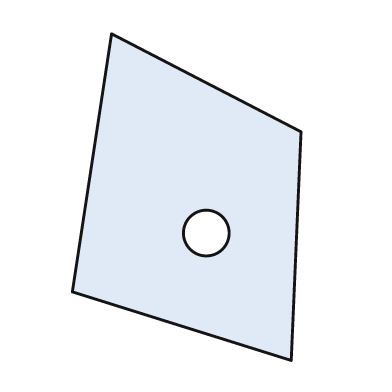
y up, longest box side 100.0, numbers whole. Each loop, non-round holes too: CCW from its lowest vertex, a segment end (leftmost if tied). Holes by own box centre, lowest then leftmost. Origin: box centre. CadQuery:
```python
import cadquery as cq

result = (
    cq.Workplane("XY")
    .moveTo(32.0, -50.0)
    .lineTo(35.0, 20.0)
    .lineTo(-23.0, 50.0)
    .lineTo(-35.0, -29.0)
    .close()
    .moveTo(6.0, -11.0)
    .circle(7.0)
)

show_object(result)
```